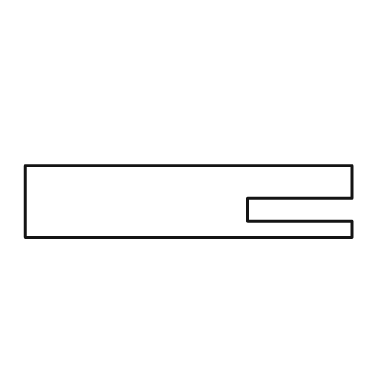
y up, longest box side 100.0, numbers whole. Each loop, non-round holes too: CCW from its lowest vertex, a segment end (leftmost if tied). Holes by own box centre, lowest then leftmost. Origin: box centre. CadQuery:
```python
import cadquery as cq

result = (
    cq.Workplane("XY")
    .moveTo(-50.0, -11.0)
    .lineTo(50.0, -11.0)
    .lineTo(50.0, -6.0)
    .lineTo(18.0, -6.0)
    .lineTo(18.0, 1.0)
    .lineTo(50.0, 1.0)
    .lineTo(50.0, 11.0)
    .lineTo(-50.0, 11.0)
    .close()
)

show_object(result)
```